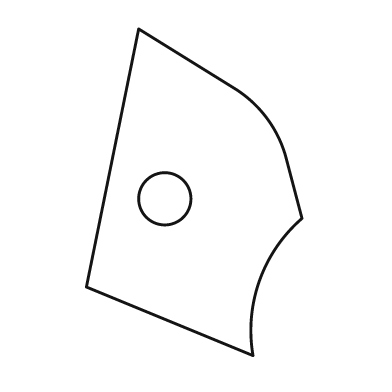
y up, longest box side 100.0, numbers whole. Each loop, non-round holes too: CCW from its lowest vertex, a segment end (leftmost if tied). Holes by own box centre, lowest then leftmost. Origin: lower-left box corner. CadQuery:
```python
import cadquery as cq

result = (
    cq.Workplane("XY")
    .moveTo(51.0, 0.0)
    .threePointArc((53.0, 23.0), (66.0, 42.0))
    .lineTo(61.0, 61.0)
    .threePointArc((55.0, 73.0), (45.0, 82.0))
    .lineTo(16.0, 100.0)
    .lineTo(0.0, 21.0)
    .close()
    .moveTo(24.0, 48.0)
    .circle(8.0)
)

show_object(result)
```